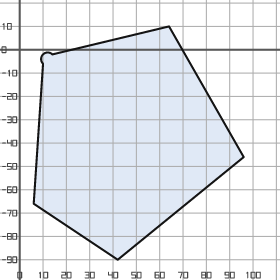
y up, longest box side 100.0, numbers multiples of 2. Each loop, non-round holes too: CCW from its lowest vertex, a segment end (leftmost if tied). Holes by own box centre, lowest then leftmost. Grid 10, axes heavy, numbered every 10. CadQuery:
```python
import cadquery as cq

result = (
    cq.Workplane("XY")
    .moveTo(42.0, -90.0)
    .lineTo(96.0, -46.0)
    .lineTo(64.0, 10.0)
    .lineTo(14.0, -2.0)
    .threePointArc((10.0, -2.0), (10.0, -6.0))
    .lineTo(6.0, -66.0)
    .close()
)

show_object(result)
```